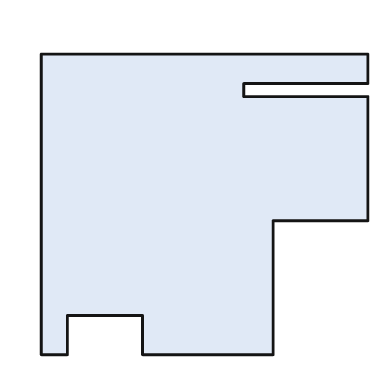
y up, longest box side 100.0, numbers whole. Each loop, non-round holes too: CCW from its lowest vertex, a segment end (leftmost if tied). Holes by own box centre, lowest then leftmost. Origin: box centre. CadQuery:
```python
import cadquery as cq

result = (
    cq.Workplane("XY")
    .moveTo(-50.0, -46.0)
    .lineTo(-42.0, -46.0)
    .lineTo(-42.0, -34.0)
    .lineTo(-19.0, -34.0)
    .lineTo(-19.0, -46.0)
    .lineTo(21.0, -46.0)
    .lineTo(21.0, -5.0)
    .lineTo(50.0, -5.0)
    .lineTo(50.0, 33.0)
    .lineTo(12.0, 33.0)
    .lineTo(12.0, 37.0)
    .lineTo(50.0, 37.0)
    .lineTo(50.0, 46.0)
    .lineTo(-50.0, 46.0)
    .close()
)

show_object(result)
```